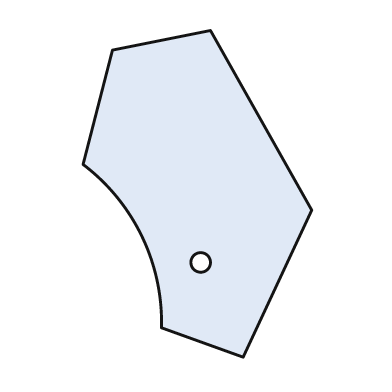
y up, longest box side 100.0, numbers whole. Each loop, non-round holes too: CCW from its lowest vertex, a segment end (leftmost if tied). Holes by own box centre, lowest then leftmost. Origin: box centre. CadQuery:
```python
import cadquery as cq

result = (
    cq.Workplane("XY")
    .moveTo(14.0, -50.0)
    .lineTo(35.0, -5.0)
    .lineTo(4.0, 50.0)
    .lineTo(-26.0, 44.0)
    .lineTo(-35.0, 9.0)
    .threePointArc((-17.0, -13.0), (-11.0, -41.0))
    .close()
    .moveTo(1.0, -21.0)
    .circle(3.0)
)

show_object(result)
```